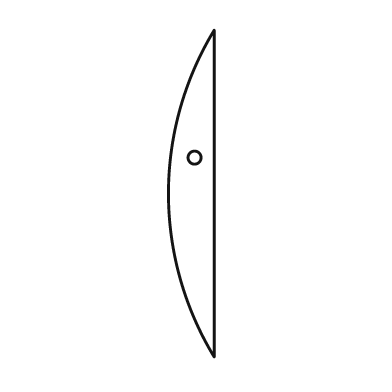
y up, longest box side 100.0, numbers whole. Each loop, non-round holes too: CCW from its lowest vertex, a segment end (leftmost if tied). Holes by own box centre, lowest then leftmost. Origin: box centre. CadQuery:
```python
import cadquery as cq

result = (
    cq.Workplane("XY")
    .moveTo(7.0, -50.0)
    .lineTo(7.0, 50.0)
    .threePointArc((-7.0, 0.0), (7.0, -50.0))
    .close()
    .moveTo(1.0, 11.0)
    .circle(2.0)
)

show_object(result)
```